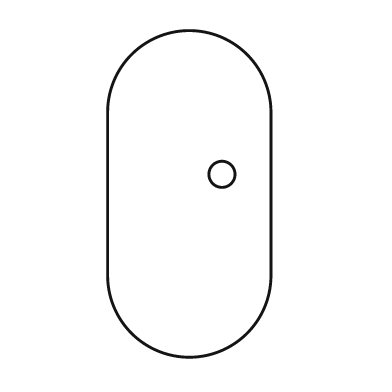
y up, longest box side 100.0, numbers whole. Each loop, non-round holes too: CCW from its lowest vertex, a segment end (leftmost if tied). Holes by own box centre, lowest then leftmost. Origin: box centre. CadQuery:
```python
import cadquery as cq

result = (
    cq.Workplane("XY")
    .moveTo(-25.0, -25.0)
    .threePointArc((0.0, -50.0), (25.0, -25.0))
    .lineTo(25.0, 25.0)
    .threePointArc((0.0, 50.0), (-25.0, 25.0))
    .close()
    .moveTo(10.0, 6.0)
    .circle(4.0)
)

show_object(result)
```